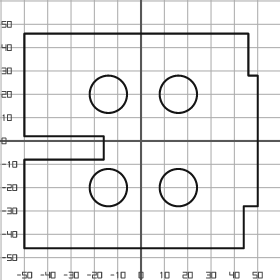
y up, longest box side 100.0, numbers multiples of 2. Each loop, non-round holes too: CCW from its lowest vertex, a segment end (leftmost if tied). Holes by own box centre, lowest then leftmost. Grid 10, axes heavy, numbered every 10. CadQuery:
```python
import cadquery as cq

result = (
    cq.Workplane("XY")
    .moveTo(-50.0, -46.0)
    .lineTo(44.0, -46.0)
    .lineTo(44.0, -28.0)
    .lineTo(50.0, -28.0)
    .lineTo(50.0, 28.0)
    .lineTo(46.0, 28.0)
    .lineTo(46.0, 46.0)
    .lineTo(-50.0, 46.0)
    .lineTo(-50.0, 2.0)
    .lineTo(-16.0, 2.0)
    .lineTo(-16.0, -8.0)
    .lineTo(-50.0, -8.0)
    .close()
    .moveTo(-14.0, -20.0)
    .circle(8.0)
    .moveTo(16.0, -20.0)
    .circle(8.0)
    .moveTo(-14.0, 20.0)
    .circle(8.0)
    .moveTo(16.0, 20.0)
    .circle(8.0)
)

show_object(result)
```